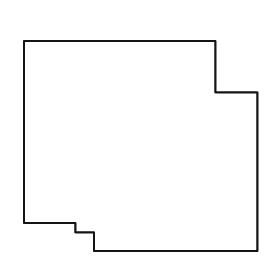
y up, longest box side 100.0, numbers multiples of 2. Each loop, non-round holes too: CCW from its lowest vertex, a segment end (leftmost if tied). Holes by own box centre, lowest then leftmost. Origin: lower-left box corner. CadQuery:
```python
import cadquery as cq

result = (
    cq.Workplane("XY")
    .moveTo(30.0, 0.0)
    .lineTo(100.0, 0.0)
    .lineTo(100.0, 68.0)
    .lineTo(82.0, 68.0)
    .lineTo(82.0, 90.0)
    .lineTo(0.0, 90.0)
    .lineTo(0.0, 12.0)
    .lineTo(22.0, 12.0)
    .lineTo(22.0, 8.0)
    .lineTo(30.0, 8.0)
    .close()
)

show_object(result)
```